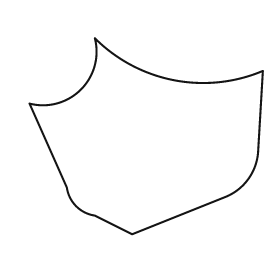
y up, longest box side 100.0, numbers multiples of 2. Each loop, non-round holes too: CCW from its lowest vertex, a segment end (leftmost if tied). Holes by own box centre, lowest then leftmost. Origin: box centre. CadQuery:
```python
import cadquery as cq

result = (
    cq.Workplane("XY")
    .moveTo(-6.0, -42.0)
    .lineTo(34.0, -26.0)
    .threePointArc((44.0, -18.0), (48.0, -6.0))
    .lineTo(50.0, 28.0)
    .threePointArc((12.0, 24.0), (-22.0, 42.0))
    .threePointArc((-28.0, 20.0), (-50.0, 14.0))
    .lineTo(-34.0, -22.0)
    .threePointArc((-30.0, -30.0), (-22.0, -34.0))
    .close()
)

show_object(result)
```